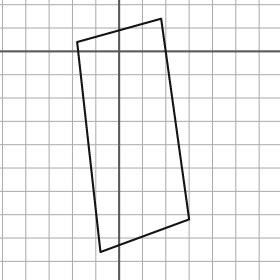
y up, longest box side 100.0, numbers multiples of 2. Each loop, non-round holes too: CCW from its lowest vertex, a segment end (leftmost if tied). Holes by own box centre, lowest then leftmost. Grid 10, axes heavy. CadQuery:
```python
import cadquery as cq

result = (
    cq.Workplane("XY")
    .moveTo(-8.0, -86.0)
    .lineTo(30.0, -72.0)
    .lineTo(18.0, 14.0)
    .lineTo(-18.0, 4.0)
    .close()
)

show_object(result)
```